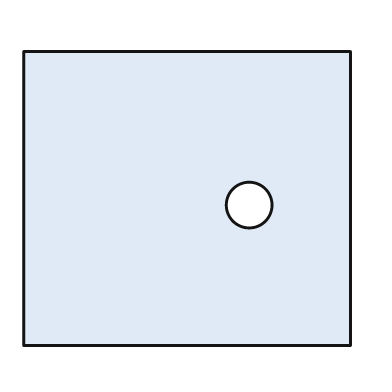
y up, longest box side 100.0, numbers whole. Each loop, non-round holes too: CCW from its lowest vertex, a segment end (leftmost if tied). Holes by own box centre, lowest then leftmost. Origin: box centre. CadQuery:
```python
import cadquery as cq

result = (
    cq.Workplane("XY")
    .moveTo(-50.0, -45.0)
    .lineTo(50.0, -45.0)
    .lineTo(50.0, 45.0)
    .lineTo(-50.0, 45.0)
    .close()
    .moveTo(19.0, -2.0)
    .circle(7.0)
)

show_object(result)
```